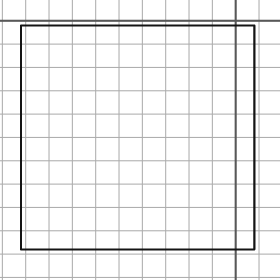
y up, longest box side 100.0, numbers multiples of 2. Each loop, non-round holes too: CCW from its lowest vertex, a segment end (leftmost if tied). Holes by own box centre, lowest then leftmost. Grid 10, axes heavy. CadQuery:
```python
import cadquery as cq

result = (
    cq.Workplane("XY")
    .moveTo(-92.0, -98.0)
    .lineTo(8.0, -98.0)
    .lineTo(8.0, -2.0)
    .lineTo(-92.0, -2.0)
    .close()
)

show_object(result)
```